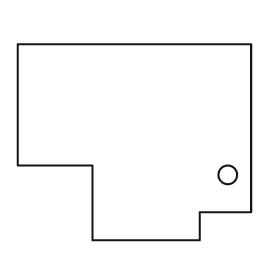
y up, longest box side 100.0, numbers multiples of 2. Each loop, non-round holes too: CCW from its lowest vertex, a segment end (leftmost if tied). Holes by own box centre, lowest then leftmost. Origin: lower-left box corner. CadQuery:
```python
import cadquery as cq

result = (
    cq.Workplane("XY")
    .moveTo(32.0, 0.0)
    .lineTo(78.0, 0.0)
    .lineTo(78.0, 12.0)
    .lineTo(100.0, 12.0)
    .lineTo(100.0, 84.0)
    .lineTo(0.0, 84.0)
    .lineTo(0.0, 32.0)
    .lineTo(32.0, 32.0)
    .close()
    .moveTo(90.0, 28.0)
    .circle(4.0)
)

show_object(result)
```